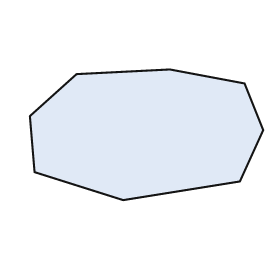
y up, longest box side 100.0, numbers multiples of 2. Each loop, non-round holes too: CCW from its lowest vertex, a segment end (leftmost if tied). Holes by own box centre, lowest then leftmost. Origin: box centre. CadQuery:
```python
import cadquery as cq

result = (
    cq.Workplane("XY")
    .moveTo(-10.0, -28.0)
    .lineTo(40.0, -20.0)
    .lineTo(50.0, 2.0)
    .lineTo(42.0, 22.0)
    .lineTo(10.0, 28.0)
    .lineTo(-30.0, 26.0)
    .lineTo(-50.0, 8.0)
    .lineTo(-48.0, -16.0)
    .close()
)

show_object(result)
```